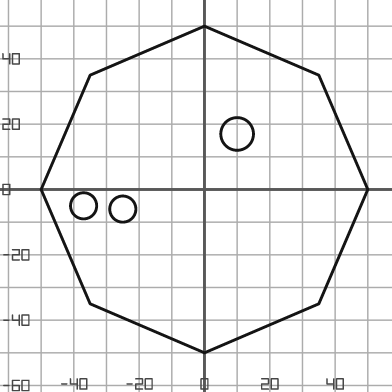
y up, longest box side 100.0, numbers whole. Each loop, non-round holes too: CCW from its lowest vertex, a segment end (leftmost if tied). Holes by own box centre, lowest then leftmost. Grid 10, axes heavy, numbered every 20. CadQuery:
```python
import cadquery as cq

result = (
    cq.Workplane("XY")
    .moveTo(0.0, -50.0)
    .lineTo(35.0, -35.0)
    .lineTo(50.0, 0.0)
    .lineTo(35.0, 35.0)
    .lineTo(0.0, 50.0)
    .lineTo(-35.0, 35.0)
    .lineTo(-50.0, 0.0)
    .lineTo(-35.0, -35.0)
    .close()
    .moveTo(-25.0, -6.0)
    .circle(4.0)
    .moveTo(-37.0, -5.0)
    .circle(4.0)
    .moveTo(10.0, 17.0)
    .circle(5.0)
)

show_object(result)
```